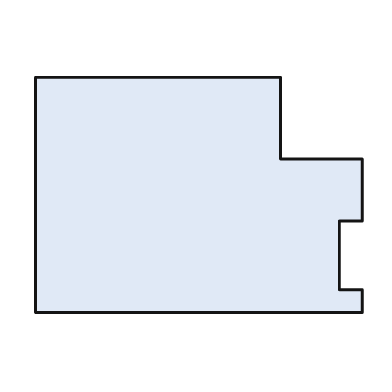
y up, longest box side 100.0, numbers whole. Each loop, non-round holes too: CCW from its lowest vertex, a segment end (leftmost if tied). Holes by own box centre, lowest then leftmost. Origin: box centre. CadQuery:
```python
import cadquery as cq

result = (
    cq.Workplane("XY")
    .moveTo(-50.0, -36.0)
    .lineTo(50.0, -36.0)
    .lineTo(50.0, -29.0)
    .lineTo(43.0, -29.0)
    .lineTo(43.0, -8.0)
    .lineTo(50.0, -8.0)
    .lineTo(50.0, 11.0)
    .lineTo(25.0, 11.0)
    .lineTo(25.0, 36.0)
    .lineTo(-50.0, 36.0)
    .close()
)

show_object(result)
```